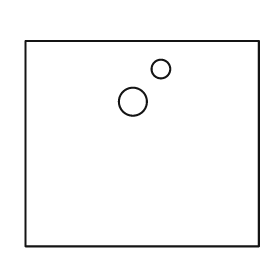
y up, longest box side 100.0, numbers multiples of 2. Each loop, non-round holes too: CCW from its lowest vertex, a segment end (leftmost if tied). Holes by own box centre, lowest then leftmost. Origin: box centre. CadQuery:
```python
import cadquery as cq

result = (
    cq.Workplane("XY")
    .moveTo(-50.0, -44.0)
    .lineTo(50.0, -44.0)
    .lineTo(50.0, 44.0)
    .lineTo(-50.0, 44.0)
    .close()
    .moveTo(-4.0, 18.0)
    .circle(6.0)
    .moveTo(8.0, 32.0)
    .circle(4.0)
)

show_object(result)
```